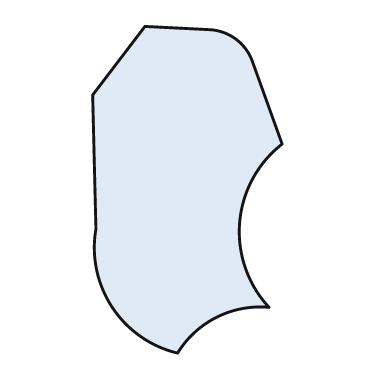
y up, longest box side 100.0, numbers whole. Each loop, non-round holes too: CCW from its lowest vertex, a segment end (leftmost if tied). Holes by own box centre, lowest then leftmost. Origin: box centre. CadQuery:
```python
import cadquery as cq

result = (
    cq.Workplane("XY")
    .moveTo(-3.0, -50.0)
    .threePointArc((9.0, -39.0), (25.0, -36.0))
    .threePointArc((16.0, -10.0), (29.0, 14.0))
    .lineTo(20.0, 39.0)
    .threePointArc((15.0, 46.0), (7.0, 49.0))
    .lineTo(-13.0, 50.0)
    .lineTo(-29.0, 29.0)
    .lineTo(-28.0, -12.0)
    .threePointArc((-23.0, -36.0), (-3.0, -50.0))
    .close()
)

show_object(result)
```